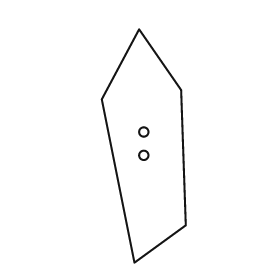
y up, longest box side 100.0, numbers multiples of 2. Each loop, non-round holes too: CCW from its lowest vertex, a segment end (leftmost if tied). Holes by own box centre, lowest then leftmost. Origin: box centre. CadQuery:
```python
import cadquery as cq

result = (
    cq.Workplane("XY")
    .moveTo(-4.0, -50.0)
    .lineTo(18.0, -34.0)
    .lineTo(16.0, 24.0)
    .lineTo(-2.0, 50.0)
    .lineTo(-18.0, 20.0)
    .close()
    .moveTo(0.0, -4.0)
    .circle(2.0)
    .moveTo(0.0, 6.0)
    .circle(2.0)
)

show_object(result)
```